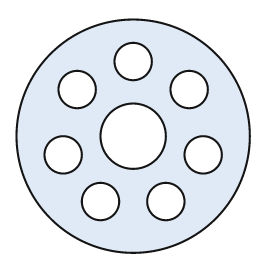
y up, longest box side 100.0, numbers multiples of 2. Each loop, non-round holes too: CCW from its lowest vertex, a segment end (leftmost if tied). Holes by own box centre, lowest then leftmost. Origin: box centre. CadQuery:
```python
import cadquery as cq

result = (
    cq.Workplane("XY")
    .moveTo(0.0, 0.0)
    .circle(50.0)
    .moveTo(-14.0, -28.0)
    .circle(8.0)
    .moveTo(14.0, -28.0)
    .circle(8.0)
    .moveTo(-30.0, -8.0)
    .circle(8.0)
    .moveTo(30.0, -8.0)
    .circle(8.0)
    .moveTo(0.0, 0.0)
    .circle(14.0)
    .moveTo(-24.0, 20.0)
    .circle(8.0)
    .moveTo(24.0, 20.0)
    .circle(8.0)
    .moveTo(0.0, 32.0)
    .circle(8.0)
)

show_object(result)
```